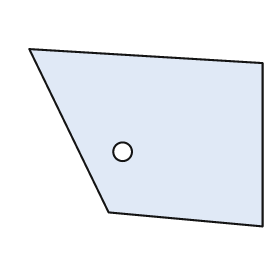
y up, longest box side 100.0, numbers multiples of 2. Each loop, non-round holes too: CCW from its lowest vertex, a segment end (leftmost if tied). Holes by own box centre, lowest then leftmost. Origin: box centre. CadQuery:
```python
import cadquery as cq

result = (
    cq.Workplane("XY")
    .moveTo(50.0, -38.0)
    .lineTo(50.0, 32.0)
    .lineTo(-50.0, 38.0)
    .lineTo(-16.0, -32.0)
    .close()
    .moveTo(-10.0, -6.0)
    .circle(4.0)
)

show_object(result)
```